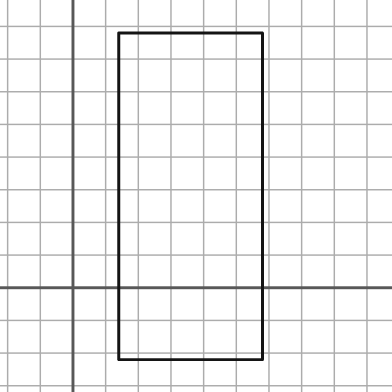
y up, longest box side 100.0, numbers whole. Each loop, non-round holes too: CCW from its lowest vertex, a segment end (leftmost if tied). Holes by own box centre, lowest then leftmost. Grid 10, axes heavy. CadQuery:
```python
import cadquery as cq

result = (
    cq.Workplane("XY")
    .moveTo(14.0, -22.0)
    .lineTo(58.0, -22.0)
    .lineTo(58.0, 78.0)
    .lineTo(14.0, 78.0)
    .close()
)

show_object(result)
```